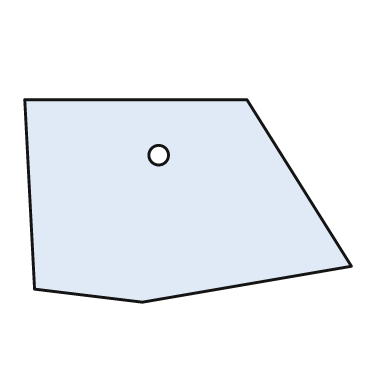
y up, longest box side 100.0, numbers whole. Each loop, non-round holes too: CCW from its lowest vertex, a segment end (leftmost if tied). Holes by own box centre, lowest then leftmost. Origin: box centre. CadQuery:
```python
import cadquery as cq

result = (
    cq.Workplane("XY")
    .moveTo(-14.0, -31.0)
    .lineTo(50.0, -20.0)
    .lineTo(18.0, 31.0)
    .lineTo(-50.0, 31.0)
    .lineTo(-47.0, -27.0)
    .close()
    .moveTo(-9.0, 14.0)
    .circle(3.0)
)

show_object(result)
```